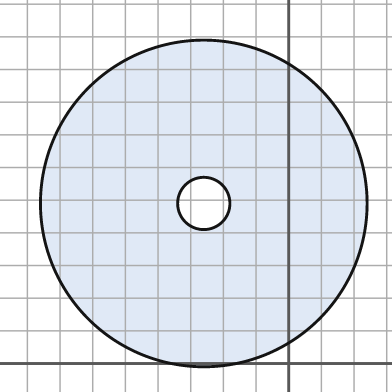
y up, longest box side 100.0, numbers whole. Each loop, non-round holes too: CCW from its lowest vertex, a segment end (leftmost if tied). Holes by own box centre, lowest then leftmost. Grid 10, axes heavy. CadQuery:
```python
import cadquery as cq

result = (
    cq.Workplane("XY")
    .moveTo(-26.0, 49.0)
    .circle(50.0)
    .moveTo(-26.0, 49.0)
    .circle(8.0)
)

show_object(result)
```